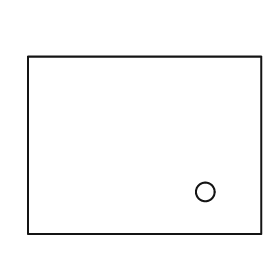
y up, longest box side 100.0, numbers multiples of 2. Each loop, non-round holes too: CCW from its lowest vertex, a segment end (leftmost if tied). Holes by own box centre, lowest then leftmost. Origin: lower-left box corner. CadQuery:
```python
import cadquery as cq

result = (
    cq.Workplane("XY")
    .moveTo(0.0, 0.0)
    .lineTo(100.0, 0.0)
    .lineTo(100.0, 76.0)
    .lineTo(0.0, 76.0)
    .close()
    .moveTo(76.0, 18.0)
    .circle(4.0)
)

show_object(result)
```